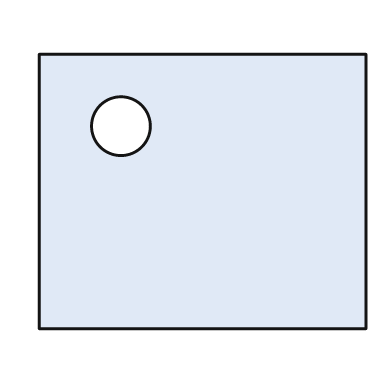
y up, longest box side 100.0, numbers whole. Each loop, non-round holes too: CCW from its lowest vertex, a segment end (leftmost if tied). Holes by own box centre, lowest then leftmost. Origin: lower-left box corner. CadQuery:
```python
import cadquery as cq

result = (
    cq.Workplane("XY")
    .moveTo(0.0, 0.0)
    .lineTo(100.0, 0.0)
    .lineTo(100.0, 84.0)
    .lineTo(0.0, 84.0)
    .close()
    .moveTo(25.0, 62.0)
    .circle(9.0)
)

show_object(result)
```